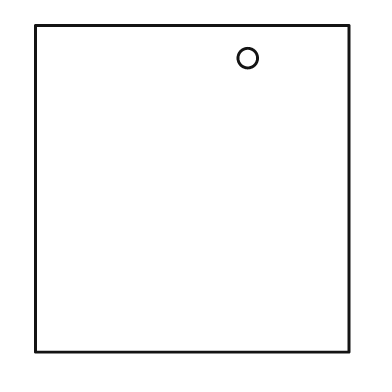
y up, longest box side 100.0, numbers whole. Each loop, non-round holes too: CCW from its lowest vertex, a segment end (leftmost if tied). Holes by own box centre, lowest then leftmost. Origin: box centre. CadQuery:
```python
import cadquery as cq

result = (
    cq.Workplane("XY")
    .moveTo(-48.0, -50.0)
    .lineTo(48.0, -50.0)
    .lineTo(48.0, 50.0)
    .lineTo(-48.0, 50.0)
    .close()
    .moveTo(17.0, 40.0)
    .circle(3.0)
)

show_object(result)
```